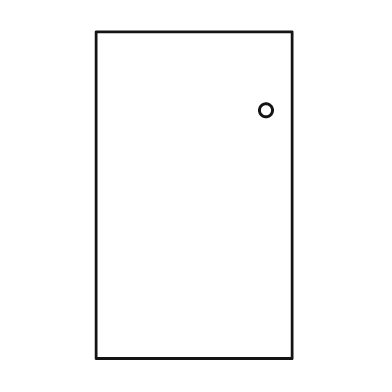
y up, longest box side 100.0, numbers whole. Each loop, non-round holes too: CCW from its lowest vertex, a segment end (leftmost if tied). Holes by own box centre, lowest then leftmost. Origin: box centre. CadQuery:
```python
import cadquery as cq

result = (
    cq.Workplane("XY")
    .moveTo(-30.0, -50.0)
    .lineTo(30.0, -50.0)
    .lineTo(30.0, 50.0)
    .lineTo(-30.0, 50.0)
    .close()
    .moveTo(22.0, 26.0)
    .circle(2.0)
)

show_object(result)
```